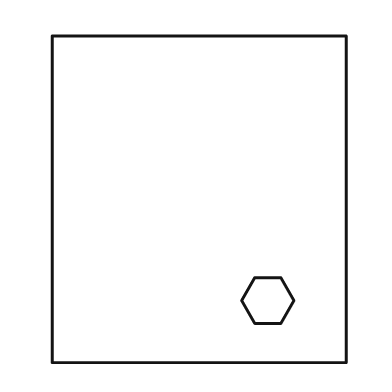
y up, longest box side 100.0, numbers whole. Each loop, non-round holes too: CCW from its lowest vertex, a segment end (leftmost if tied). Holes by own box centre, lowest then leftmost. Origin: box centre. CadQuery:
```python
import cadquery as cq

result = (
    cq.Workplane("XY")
    .moveTo(-45.0, -50.0)
    .lineTo(45.0, -50.0)
    .lineTo(45.0, 50.0)
    .lineTo(-45.0, 50.0)
    .close()
    .moveTo(17.0, -38.0)
    .lineTo(25.0, -38.0)
    .lineTo(29.0, -31.0)
    .lineTo(25.0, -24.0)
    .lineTo(17.0, -24.0)
    .lineTo(13.0, -31.0)
    .close()
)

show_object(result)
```